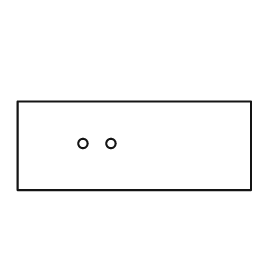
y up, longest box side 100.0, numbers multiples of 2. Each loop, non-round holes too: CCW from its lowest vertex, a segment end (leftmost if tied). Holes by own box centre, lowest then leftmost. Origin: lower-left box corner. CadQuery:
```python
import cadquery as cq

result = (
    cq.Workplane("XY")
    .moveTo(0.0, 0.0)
    .lineTo(100.0, 0.0)
    .lineTo(100.0, 38.0)
    .lineTo(0.0, 38.0)
    .close()
    .moveTo(28.0, 20.0)
    .circle(2.0)
    .moveTo(40.0, 20.0)
    .circle(2.0)
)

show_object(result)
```